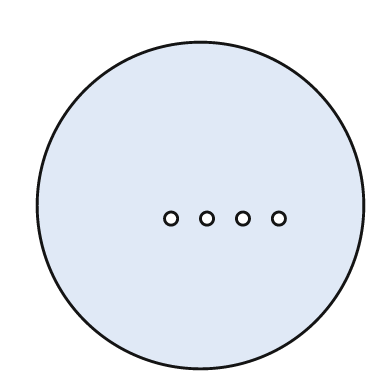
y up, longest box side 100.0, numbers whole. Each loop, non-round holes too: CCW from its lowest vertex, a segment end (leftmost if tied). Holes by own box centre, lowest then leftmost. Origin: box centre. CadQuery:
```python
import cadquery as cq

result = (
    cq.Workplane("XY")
    .moveTo(0.0, 0.0)
    .circle(50.0)
    .moveTo(-9.0, -4.0)
    .circle(2.0)
    .moveTo(2.0, -4.0)
    .circle(2.0)
    .moveTo(13.0, -4.0)
    .circle(2.0)
    .moveTo(24.0, -4.0)
    .circle(2.0)
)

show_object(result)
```